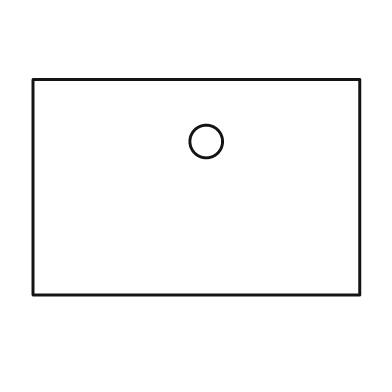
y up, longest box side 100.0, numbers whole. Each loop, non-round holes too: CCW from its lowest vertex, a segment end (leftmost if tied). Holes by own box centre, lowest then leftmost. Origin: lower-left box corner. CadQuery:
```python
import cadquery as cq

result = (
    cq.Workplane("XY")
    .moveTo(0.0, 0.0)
    .lineTo(100.0, 0.0)
    .lineTo(100.0, 66.0)
    .lineTo(0.0, 66.0)
    .close()
    .moveTo(53.0, 47.0)
    .circle(5.0)
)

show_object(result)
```